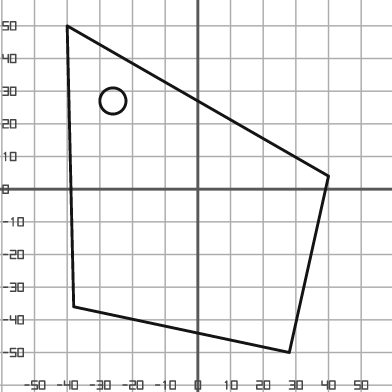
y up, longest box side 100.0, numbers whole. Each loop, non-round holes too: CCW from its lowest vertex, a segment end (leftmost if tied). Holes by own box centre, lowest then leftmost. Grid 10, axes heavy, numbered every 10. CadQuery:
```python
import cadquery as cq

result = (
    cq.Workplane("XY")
    .moveTo(28.0, -50.0)
    .lineTo(40.0, 4.0)
    .lineTo(-40.0, 50.0)
    .lineTo(-38.0, -36.0)
    .close()
    .moveTo(-26.0, 27.0)
    .circle(4.0)
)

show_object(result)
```